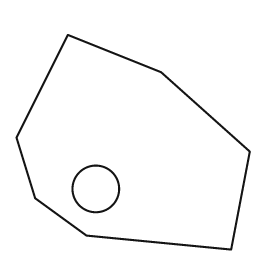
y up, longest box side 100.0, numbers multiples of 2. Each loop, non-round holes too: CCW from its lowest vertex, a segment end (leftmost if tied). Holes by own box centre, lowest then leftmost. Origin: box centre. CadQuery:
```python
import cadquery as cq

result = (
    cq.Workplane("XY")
    .moveTo(42.0, -46.0)
    .lineTo(50.0, -4.0)
    .lineTo(12.0, 30.0)
    .lineTo(-28.0, 46.0)
    .lineTo(-50.0, 2.0)
    .lineTo(-42.0, -24.0)
    .lineTo(-20.0, -40.0)
    .close()
    .moveTo(-16.0, -20.0)
    .circle(10.0)
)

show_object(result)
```